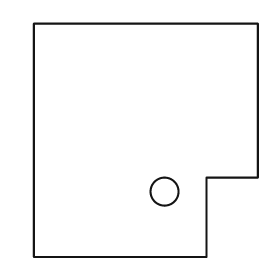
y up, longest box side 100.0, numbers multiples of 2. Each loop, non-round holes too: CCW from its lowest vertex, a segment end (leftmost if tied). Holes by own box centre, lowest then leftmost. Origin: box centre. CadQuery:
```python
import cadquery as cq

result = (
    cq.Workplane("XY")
    .moveTo(-48.0, -50.0)
    .lineTo(26.0, -50.0)
    .lineTo(26.0, -16.0)
    .lineTo(48.0, -16.0)
    .lineTo(48.0, 50.0)
    .lineTo(-48.0, 50.0)
    .close()
    .moveTo(8.0, -22.0)
    .circle(6.0)
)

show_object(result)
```